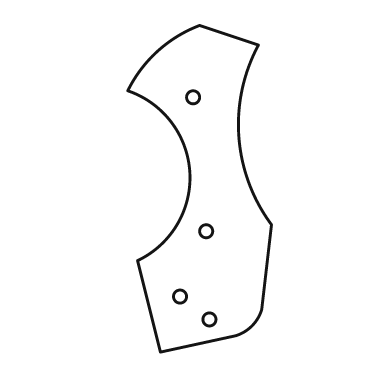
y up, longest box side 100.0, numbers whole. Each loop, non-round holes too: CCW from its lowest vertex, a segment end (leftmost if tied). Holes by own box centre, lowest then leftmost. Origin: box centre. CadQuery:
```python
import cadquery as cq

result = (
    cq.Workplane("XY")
    .moveTo(-12.0, -50.0)
    .lineTo(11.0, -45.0)
    .threePointArc((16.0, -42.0), (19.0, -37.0))
    .lineTo(22.0, -11.0)
    .threePointArc((12.0, 16.0), (18.0, 44.0))
    .lineTo(0.0, 50.0)
    .threePointArc((-13.0, 42.0), (-22.0, 30.0))
    .threePointArc((-3.0, 5.0), (-19.0, -22.0))
    .close()
    .moveTo(3.0, -40.0)
    .circle(2.0)
    .moveTo(-6.0, -33.0)
    .circle(2.0)
    .moveTo(2.0, -13.0)
    .circle(2.0)
    .moveTo(-2.0, 28.0)
    .circle(2.0)
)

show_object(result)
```